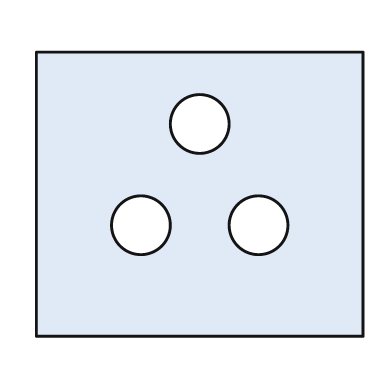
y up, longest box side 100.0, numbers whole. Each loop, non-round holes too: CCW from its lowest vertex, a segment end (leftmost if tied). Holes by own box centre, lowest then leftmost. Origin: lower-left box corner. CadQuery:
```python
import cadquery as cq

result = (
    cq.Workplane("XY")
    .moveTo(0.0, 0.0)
    .lineTo(100.0, 0.0)
    .lineTo(100.0, 87.0)
    .lineTo(0.0, 87.0)
    .close()
    .moveTo(32.0, 34.0)
    .circle(9.0)
    .moveTo(68.0, 34.0)
    .circle(9.0)
    .moveTo(50.0, 65.0)
    .circle(9.0)
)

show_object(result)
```